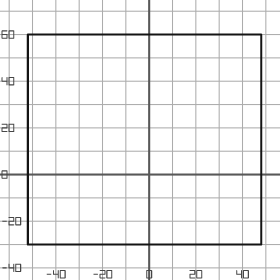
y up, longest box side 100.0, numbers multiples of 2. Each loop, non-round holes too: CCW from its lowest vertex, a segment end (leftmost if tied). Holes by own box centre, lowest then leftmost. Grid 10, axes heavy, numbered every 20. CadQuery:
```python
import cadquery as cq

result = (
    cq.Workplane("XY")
    .moveTo(-52.0, -30.0)
    .lineTo(48.0, -30.0)
    .lineTo(48.0, 60.0)
    .lineTo(-52.0, 60.0)
    .close()
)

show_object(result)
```